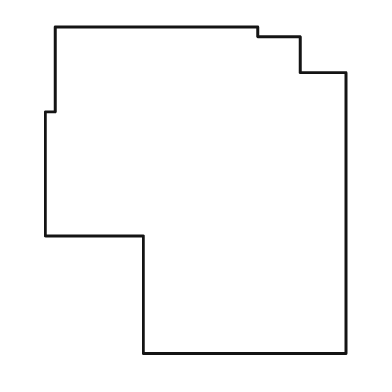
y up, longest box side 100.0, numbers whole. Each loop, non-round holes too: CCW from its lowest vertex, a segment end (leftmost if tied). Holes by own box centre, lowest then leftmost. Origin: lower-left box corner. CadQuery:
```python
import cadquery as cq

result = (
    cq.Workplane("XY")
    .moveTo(30.0, 0.0)
    .lineTo(92.0, 0.0)
    .lineTo(92.0, 86.0)
    .lineTo(78.0, 86.0)
    .lineTo(78.0, 97.0)
    .lineTo(65.0, 97.0)
    .lineTo(65.0, 100.0)
    .lineTo(3.0, 100.0)
    .lineTo(3.0, 74.0)
    .lineTo(0.0, 74.0)
    .lineTo(0.0, 36.0)
    .lineTo(30.0, 36.0)
    .close()
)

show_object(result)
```